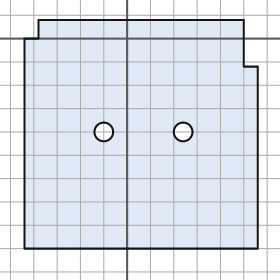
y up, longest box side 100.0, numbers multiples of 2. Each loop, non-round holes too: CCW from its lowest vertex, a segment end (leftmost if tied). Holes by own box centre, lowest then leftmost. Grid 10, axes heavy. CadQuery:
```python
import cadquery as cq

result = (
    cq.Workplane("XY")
    .moveTo(-44.0, -90.0)
    .lineTo(56.0, -90.0)
    .lineTo(56.0, -12.0)
    .lineTo(50.0, -12.0)
    .lineTo(50.0, 8.0)
    .lineTo(-38.0, 8.0)
    .lineTo(-38.0, 0.0)
    .lineTo(-44.0, 0.0)
    .close()
    .moveTo(-10.0, -40.0)
    .circle(4.0)
    .moveTo(24.0, -40.0)
    .circle(4.0)
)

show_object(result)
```